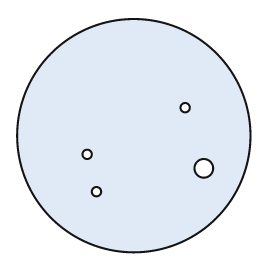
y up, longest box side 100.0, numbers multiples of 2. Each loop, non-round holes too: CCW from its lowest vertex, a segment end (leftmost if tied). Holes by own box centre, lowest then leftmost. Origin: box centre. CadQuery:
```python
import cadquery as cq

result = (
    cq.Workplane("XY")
    .moveTo(0.0, 0.0)
    .circle(50.0)
    .moveTo(-16.0, -24.0)
    .circle(2.0)
    .moveTo(30.0, -14.0)
    .circle(4.0)
    .moveTo(-20.0, -8.0)
    .circle(2.0)
    .moveTo(22.0, 12.0)
    .circle(2.0)
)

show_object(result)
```